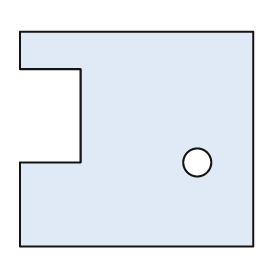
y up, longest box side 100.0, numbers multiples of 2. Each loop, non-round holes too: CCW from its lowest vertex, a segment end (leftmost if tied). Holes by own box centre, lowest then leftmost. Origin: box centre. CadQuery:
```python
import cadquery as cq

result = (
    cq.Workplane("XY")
    .moveTo(-50.0, -46.0)
    .lineTo(50.0, -46.0)
    .lineTo(50.0, 46.0)
    .lineTo(-50.0, 46.0)
    .lineTo(-50.0, 30.0)
    .lineTo(-24.0, 30.0)
    .lineTo(-24.0, -10.0)
    .lineTo(-50.0, -10.0)
    .close()
    .moveTo(26.0, -10.0)
    .circle(6.0)
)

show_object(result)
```